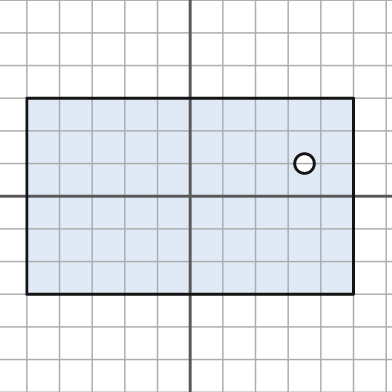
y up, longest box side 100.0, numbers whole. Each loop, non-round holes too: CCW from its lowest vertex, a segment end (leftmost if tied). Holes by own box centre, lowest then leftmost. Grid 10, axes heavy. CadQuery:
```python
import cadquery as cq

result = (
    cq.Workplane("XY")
    .moveTo(-50.0, -30.0)
    .lineTo(50.0, -30.0)
    .lineTo(50.0, 30.0)
    .lineTo(-50.0, 30.0)
    .close()
    .moveTo(35.0, 10.0)
    .circle(3.0)
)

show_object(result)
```